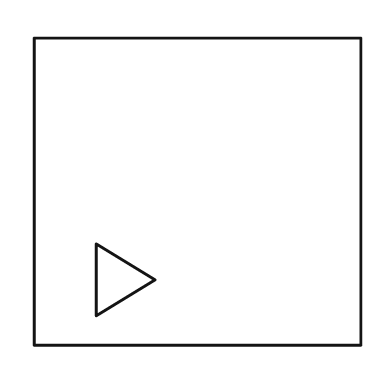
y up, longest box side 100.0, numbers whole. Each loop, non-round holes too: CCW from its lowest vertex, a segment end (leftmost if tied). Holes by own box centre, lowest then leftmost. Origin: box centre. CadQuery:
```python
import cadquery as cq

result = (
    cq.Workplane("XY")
    .moveTo(-50.0, -47.0)
    .lineTo(50.0, -47.0)
    .lineTo(50.0, 47.0)
    .lineTo(-50.0, 47.0)
    .close()
    .moveTo(-31.0, -38.0)
    .lineTo(-13.0, -27.0)
    .lineTo(-31.0, -16.0)
    .close()
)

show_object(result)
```